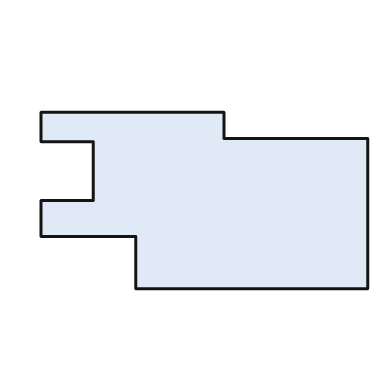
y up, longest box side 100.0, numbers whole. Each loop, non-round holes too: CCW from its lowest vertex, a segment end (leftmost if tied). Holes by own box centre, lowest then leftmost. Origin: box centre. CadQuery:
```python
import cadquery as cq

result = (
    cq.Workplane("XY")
    .moveTo(-21.0, -27.0)
    .lineTo(50.0, -27.0)
    .lineTo(50.0, 19.0)
    .lineTo(6.0, 19.0)
    .lineTo(6.0, 27.0)
    .lineTo(-50.0, 27.0)
    .lineTo(-50.0, 18.0)
    .lineTo(-34.0, 18.0)
    .lineTo(-34.0, 0.0)
    .lineTo(-50.0, 0.0)
    .lineTo(-50.0, -11.0)
    .lineTo(-21.0, -11.0)
    .close()
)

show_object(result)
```